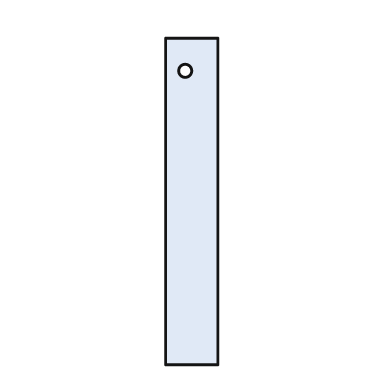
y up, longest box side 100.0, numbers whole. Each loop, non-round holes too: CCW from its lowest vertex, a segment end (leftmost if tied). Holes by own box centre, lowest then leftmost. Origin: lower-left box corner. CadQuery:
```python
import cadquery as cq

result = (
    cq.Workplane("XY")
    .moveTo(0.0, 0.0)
    .lineTo(16.0, 0.0)
    .lineTo(16.0, 100.0)
    .lineTo(0.0, 100.0)
    .close()
    .moveTo(6.0, 90.0)
    .circle(2.0)
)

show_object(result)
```